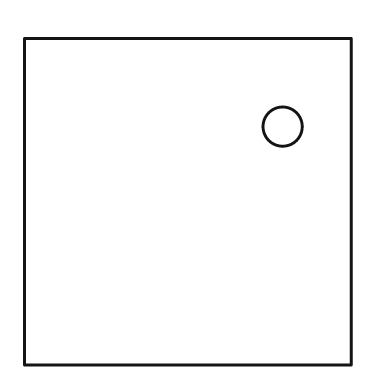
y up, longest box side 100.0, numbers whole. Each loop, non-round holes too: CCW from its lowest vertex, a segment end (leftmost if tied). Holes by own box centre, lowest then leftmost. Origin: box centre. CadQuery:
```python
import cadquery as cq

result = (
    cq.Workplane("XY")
    .moveTo(-50.0, -50.0)
    .lineTo(50.0, -50.0)
    .lineTo(50.0, 50.0)
    .lineTo(-50.0, 50.0)
    .close()
    .moveTo(29.0, 23.0)
    .circle(6.0)
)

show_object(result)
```